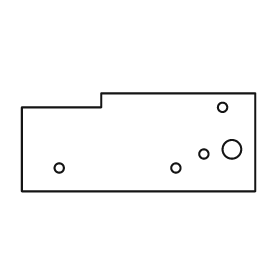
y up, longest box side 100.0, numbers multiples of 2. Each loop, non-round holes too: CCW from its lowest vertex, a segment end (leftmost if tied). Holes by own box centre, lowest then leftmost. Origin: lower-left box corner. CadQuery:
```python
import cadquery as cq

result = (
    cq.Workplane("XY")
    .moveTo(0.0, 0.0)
    .lineTo(100.0, 0.0)
    .lineTo(100.0, 42.0)
    .lineTo(34.0, 42.0)
    .lineTo(34.0, 36.0)
    .lineTo(0.0, 36.0)
    .close()
    .moveTo(16.0, 10.0)
    .circle(2.0)
    .moveTo(66.0, 10.0)
    .circle(2.0)
    .moveTo(78.0, 16.0)
    .circle(2.0)
    .moveTo(90.0, 18.0)
    .circle(4.0)
    .moveTo(86.0, 36.0)
    .circle(2.0)
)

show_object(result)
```